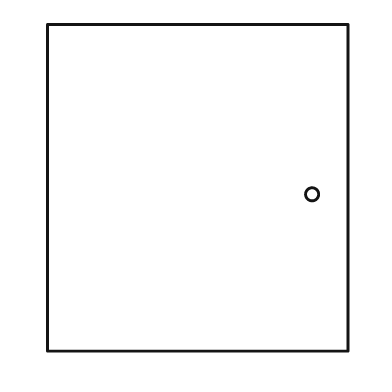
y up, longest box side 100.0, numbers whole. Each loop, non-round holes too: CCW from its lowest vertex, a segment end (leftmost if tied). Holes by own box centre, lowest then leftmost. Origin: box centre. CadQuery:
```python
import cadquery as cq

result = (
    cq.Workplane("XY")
    .moveTo(-46.0, -50.0)
    .lineTo(46.0, -50.0)
    .lineTo(46.0, 50.0)
    .lineTo(-46.0, 50.0)
    .close()
    .moveTo(35.0, -2.0)
    .circle(2.0)
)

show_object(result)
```